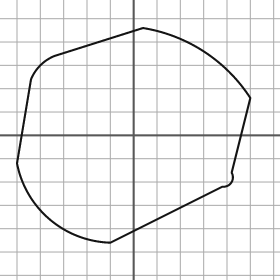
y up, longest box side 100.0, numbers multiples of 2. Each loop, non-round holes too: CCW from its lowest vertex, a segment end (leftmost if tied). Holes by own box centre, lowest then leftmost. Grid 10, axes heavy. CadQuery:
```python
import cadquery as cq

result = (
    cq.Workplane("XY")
    .moveTo(-10.0, -46.0)
    .lineTo(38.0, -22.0)
    .threePointArc((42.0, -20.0), (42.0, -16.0))
    .lineTo(50.0, 16.0)
    .threePointArc((30.0, 36.0), (4.0, 46.0))
    .lineTo(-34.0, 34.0)
    .threePointArc((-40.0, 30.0), (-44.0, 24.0))
    .lineTo(-50.0, -12.0)
    .threePointArc((-36.0, -36.0), (-10.0, -46.0))
    .close()
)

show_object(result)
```